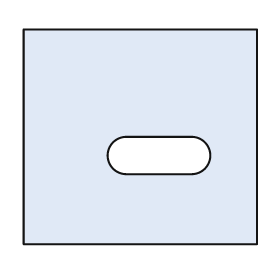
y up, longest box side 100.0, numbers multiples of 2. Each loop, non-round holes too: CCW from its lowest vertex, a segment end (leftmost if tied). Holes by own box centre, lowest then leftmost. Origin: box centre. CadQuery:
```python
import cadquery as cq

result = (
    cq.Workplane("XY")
    .moveTo(-50.0, -46.0)
    .lineTo(50.0, -46.0)
    .lineTo(50.0, 46.0)
    .lineTo(-50.0, 46.0)
    .close()
    .moveTo(-6.0, -16.0)
    .lineTo(22.0, -16.0)
    .threePointArc((30.0, -8.0), (22.0, 0.0))
    .lineTo(-6.0, 0.0)
    .threePointArc((-14.0, -8.0), (-6.0, -16.0))
    .close()
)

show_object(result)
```